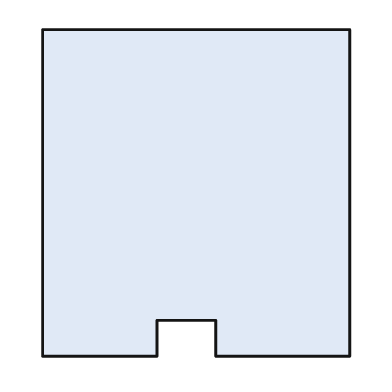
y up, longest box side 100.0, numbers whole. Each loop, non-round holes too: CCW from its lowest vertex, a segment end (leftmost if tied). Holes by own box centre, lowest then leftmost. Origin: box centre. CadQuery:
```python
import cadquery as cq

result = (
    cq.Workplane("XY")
    .moveTo(-47.0, -50.0)
    .lineTo(-12.0, -50.0)
    .lineTo(-12.0, -39.0)
    .lineTo(6.0, -39.0)
    .lineTo(6.0, -50.0)
    .lineTo(47.0, -50.0)
    .lineTo(47.0, 50.0)
    .lineTo(-47.0, 50.0)
    .close()
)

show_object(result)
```